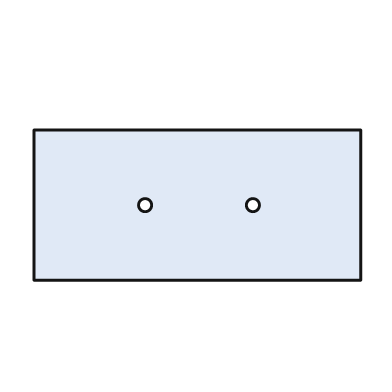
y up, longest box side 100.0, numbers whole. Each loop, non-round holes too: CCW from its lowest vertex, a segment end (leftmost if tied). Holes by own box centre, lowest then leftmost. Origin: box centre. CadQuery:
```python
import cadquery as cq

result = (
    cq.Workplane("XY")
    .moveTo(-50.0, -23.0)
    .lineTo(50.0, -23.0)
    .lineTo(50.0, 23.0)
    .lineTo(-50.0, 23.0)
    .close()
    .moveTo(-16.0, 0.0)
    .circle(2.0)
    .moveTo(17.0, 0.0)
    .circle(2.0)
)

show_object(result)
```